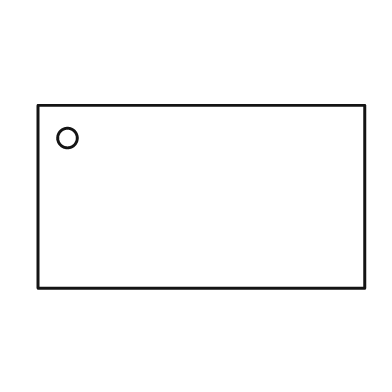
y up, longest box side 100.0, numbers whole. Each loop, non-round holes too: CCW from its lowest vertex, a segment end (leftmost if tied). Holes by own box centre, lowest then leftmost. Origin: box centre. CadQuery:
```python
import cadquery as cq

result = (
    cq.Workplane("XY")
    .moveTo(-50.0, -28.0)
    .lineTo(50.0, -28.0)
    .lineTo(50.0, 28.0)
    .lineTo(-50.0, 28.0)
    .close()
    .moveTo(-41.0, 18.0)
    .circle(3.0)
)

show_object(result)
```